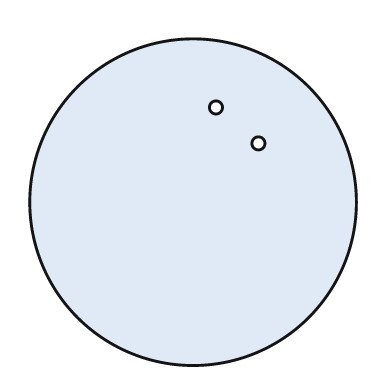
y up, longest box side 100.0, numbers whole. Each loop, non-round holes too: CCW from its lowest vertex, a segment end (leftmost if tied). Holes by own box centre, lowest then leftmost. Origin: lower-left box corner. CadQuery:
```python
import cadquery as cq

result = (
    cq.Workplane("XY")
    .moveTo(50.0, 50.0)
    .circle(50.0)
    .moveTo(70.0, 68.0)
    .circle(2.0)
    .moveTo(57.0, 79.0)
    .circle(2.0)
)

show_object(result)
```